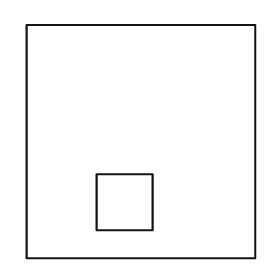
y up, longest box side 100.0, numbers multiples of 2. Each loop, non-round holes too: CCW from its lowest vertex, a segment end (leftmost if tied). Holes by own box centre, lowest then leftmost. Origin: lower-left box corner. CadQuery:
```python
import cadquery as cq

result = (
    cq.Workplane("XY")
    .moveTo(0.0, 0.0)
    .lineTo(98.0, 0.0)
    .lineTo(98.0, 100.0)
    .lineTo(0.0, 100.0)
    .close()
    .moveTo(30.0, 12.0)
    .lineTo(54.0, 12.0)
    .lineTo(54.0, 36.0)
    .lineTo(30.0, 36.0)
    .close()
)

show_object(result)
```